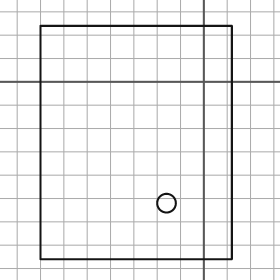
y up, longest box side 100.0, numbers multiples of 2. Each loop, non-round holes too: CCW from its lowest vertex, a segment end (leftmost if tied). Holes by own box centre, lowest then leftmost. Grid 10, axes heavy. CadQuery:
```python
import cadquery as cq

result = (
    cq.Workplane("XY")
    .moveTo(-70.0, -76.0)
    .lineTo(12.0, -76.0)
    .lineTo(12.0, 24.0)
    .lineTo(-70.0, 24.0)
    .close()
    .moveTo(-16.0, -52.0)
    .circle(4.0)
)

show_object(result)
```